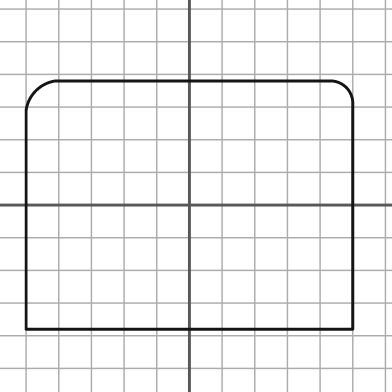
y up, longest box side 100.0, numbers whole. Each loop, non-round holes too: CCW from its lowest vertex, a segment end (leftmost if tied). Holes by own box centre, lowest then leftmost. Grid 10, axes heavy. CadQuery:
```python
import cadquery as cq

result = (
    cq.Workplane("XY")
    .moveTo(-50.0, -38.0)
    .lineTo(50.0, -38.0)
    .lineTo(50.0, 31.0)
    .threePointArc((48.0, 36.0), (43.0, 38.0))
    .lineTo(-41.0, 38.0)
    .threePointArc((-47.0, 35.0), (-50.0, 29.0))
    .close()
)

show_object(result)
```